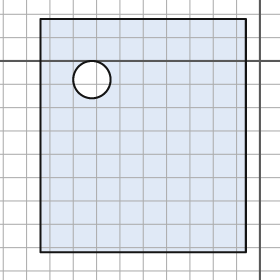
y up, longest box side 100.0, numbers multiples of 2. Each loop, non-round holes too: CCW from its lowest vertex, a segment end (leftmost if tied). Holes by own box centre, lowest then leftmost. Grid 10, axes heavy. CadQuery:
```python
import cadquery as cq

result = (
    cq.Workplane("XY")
    .moveTo(-94.0, -82.0)
    .lineTo(-6.0, -82.0)
    .lineTo(-6.0, 18.0)
    .lineTo(-94.0, 18.0)
    .close()
    .moveTo(-72.0, -8.0)
    .circle(8.0)
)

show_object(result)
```